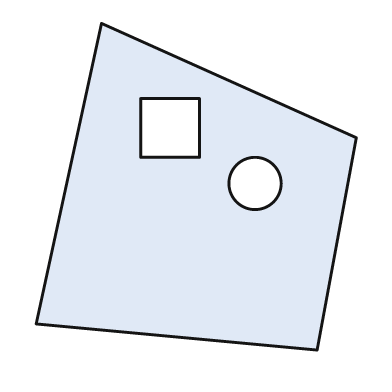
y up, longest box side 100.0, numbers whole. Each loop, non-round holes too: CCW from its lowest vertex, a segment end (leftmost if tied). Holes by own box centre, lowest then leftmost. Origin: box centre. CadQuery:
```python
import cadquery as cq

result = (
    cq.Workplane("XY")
    .moveTo(37.0, -50.0)
    .lineTo(49.0, 15.0)
    .lineTo(-29.0, 50.0)
    .lineTo(-49.0, -42.0)
    .close()
    .moveTo(18.0, 1.0)
    .circle(8.0)
    .moveTo(-17.0, 9.0)
    .lineTo(1.0, 9.0)
    .lineTo(1.0, 27.0)
    .lineTo(-17.0, 27.0)
    .close()
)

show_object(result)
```